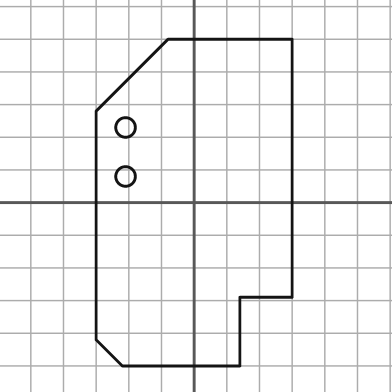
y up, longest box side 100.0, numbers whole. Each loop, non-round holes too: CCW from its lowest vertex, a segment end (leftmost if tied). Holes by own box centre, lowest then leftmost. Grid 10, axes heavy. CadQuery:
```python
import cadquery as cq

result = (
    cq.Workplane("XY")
    .moveTo(-22.0, -50.0)
    .lineTo(14.0, -50.0)
    .lineTo(14.0, -29.0)
    .lineTo(30.0, -29.0)
    .lineTo(30.0, 50.0)
    .lineTo(-8.0, 50.0)
    .lineTo(-30.0, 28.0)
    .lineTo(-30.0, -42.0)
    .close()
    .moveTo(-21.0, 8.0)
    .circle(3.0)
    .moveTo(-21.0, 23.0)
    .circle(3.0)
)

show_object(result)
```